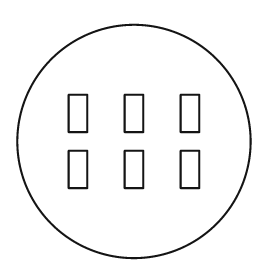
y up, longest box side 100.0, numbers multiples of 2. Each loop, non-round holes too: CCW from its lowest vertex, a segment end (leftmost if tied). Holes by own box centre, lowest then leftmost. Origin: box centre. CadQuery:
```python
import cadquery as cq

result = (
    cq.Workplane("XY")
    .moveTo(0.0, 0.0)
    .circle(50.0)
    .moveTo(-28.0, -20.0)
    .lineTo(-20.0, -20.0)
    .lineTo(-20.0, -4.0)
    .lineTo(-28.0, -4.0)
    .close()
    .moveTo(-4.0, -20.0)
    .lineTo(4.0, -20.0)
    .lineTo(4.0, -4.0)
    .lineTo(-4.0, -4.0)
    .close()
    .moveTo(20.0, -20.0)
    .lineTo(28.0, -20.0)
    .lineTo(28.0, -4.0)
    .lineTo(20.0, -4.0)
    .close()
    .moveTo(-28.0, 4.0)
    .lineTo(-20.0, 4.0)
    .lineTo(-20.0, 20.0)
    .lineTo(-28.0, 20.0)
    .close()
    .moveTo(-4.0, 4.0)
    .lineTo(4.0, 4.0)
    .lineTo(4.0, 20.0)
    .lineTo(-4.0, 20.0)
    .close()
    .moveTo(20.0, 4.0)
    .lineTo(28.0, 4.0)
    .lineTo(28.0, 20.0)
    .lineTo(20.0, 20.0)
    .close()
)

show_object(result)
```